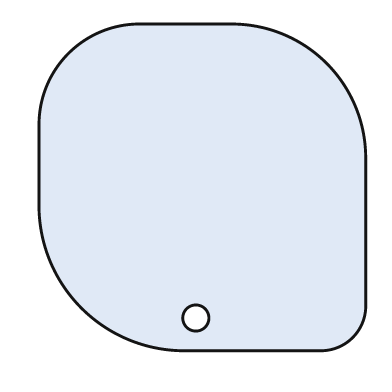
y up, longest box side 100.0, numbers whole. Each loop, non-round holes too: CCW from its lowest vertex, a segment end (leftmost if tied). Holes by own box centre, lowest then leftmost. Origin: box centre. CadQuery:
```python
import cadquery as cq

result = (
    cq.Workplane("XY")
    .moveTo(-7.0, -50.0)
    .lineTo(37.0, -50.0)
    .threePointArc((46.0, -46.0), (50.0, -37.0))
    .lineTo(50.0, 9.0)
    .threePointArc((38.0, 38.0), (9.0, 50.0))
    .lineTo(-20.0, 50.0)
    .threePointArc((-41.0, 41.0), (-50.0, 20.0))
    .lineTo(-50.0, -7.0)
    .threePointArc((-37.0, -37.0), (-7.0, -50.0))
    .close()
    .moveTo(-2.0, -40.0)
    .circle(4.0)
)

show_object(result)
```